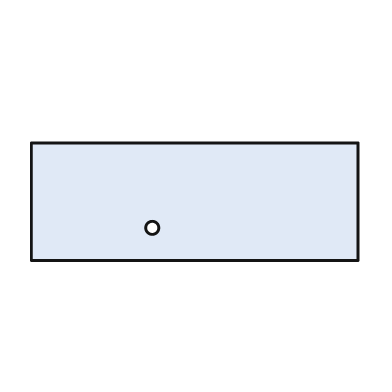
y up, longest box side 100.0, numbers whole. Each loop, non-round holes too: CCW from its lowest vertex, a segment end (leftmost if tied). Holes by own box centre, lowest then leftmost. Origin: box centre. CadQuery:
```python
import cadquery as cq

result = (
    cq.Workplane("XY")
    .moveTo(-50.0, -18.0)
    .lineTo(50.0, -18.0)
    .lineTo(50.0, 18.0)
    .lineTo(-50.0, 18.0)
    .close()
    .moveTo(-13.0, -8.0)
    .circle(2.0)
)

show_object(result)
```